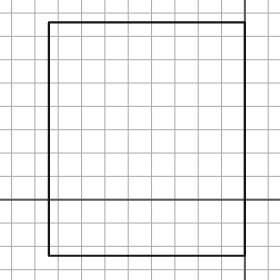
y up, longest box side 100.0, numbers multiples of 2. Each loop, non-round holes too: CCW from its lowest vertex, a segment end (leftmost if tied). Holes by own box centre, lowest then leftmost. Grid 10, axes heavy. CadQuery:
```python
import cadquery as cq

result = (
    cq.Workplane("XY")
    .moveTo(-84.0, -24.0)
    .lineTo(0.0, -24.0)
    .lineTo(0.0, 76.0)
    .lineTo(-84.0, 76.0)
    .close()
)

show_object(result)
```